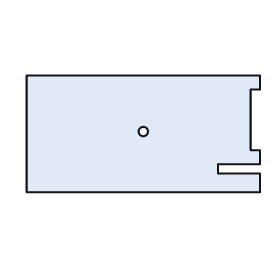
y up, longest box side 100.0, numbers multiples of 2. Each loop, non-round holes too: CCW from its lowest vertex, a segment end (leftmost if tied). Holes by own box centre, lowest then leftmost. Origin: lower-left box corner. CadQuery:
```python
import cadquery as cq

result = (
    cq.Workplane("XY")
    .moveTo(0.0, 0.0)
    .lineTo(100.0, 0.0)
    .lineTo(100.0, 8.0)
    .lineTo(82.0, 8.0)
    .lineTo(82.0, 12.0)
    .lineTo(100.0, 12.0)
    .lineTo(100.0, 18.0)
    .lineTo(96.0, 18.0)
    .lineTo(96.0, 44.0)
    .lineTo(100.0, 44.0)
    .lineTo(100.0, 50.0)
    .lineTo(0.0, 50.0)
    .close()
    .moveTo(50.0, 26.0)
    .circle(2.0)
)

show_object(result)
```